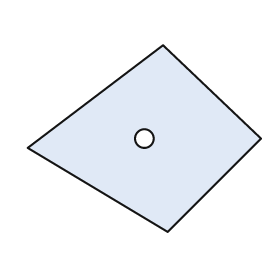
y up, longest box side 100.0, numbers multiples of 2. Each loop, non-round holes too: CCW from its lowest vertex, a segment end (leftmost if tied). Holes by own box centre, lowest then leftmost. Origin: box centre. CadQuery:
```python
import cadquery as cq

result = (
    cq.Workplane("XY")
    .moveTo(10.0, -40.0)
    .lineTo(50.0, 0.0)
    .lineTo(8.0, 40.0)
    .lineTo(-50.0, -4.0)
    .close()
    .moveTo(0.0, 0.0)
    .circle(4.0)
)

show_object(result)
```